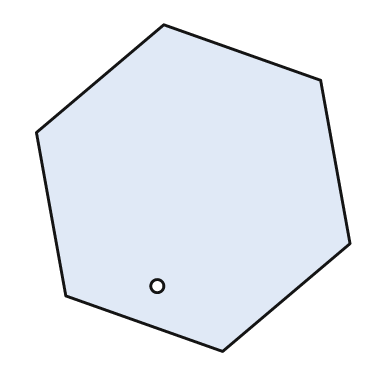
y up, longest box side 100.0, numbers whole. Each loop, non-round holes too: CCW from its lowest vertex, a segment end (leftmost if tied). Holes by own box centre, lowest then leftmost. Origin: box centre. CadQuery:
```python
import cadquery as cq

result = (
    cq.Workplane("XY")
    .moveTo(9.0, -50.0)
    .lineTo(48.0, -17.0)
    .lineTo(39.0, 33.0)
    .lineTo(-9.0, 50.0)
    .lineTo(-48.0, 17.0)
    .lineTo(-39.0, -33.0)
    .close()
    .moveTo(-11.0, -30.0)
    .circle(2.0)
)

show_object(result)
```